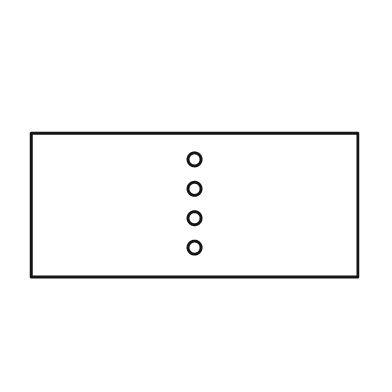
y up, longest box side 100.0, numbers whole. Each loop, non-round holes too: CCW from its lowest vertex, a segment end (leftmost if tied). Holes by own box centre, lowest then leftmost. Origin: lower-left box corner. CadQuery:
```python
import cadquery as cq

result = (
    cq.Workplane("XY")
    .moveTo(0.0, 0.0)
    .lineTo(100.0, 0.0)
    .lineTo(100.0, 44.0)
    .lineTo(0.0, 44.0)
    .close()
    .moveTo(50.0, 9.0)
    .circle(2.0)
    .moveTo(50.0, 18.0)
    .circle(2.0)
    .moveTo(50.0, 27.0)
    .circle(2.0)
    .moveTo(50.0, 36.0)
    .circle(2.0)
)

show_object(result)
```